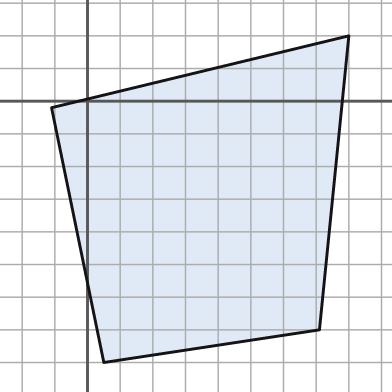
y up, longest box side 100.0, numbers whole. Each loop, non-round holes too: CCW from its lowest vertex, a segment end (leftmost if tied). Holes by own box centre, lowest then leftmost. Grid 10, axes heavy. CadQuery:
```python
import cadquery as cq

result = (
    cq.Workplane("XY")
    .moveTo(5.0, -80.0)
    .lineTo(71.0, -70.0)
    .lineTo(80.0, 20.0)
    .lineTo(-11.0, -2.0)
    .close()
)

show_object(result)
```